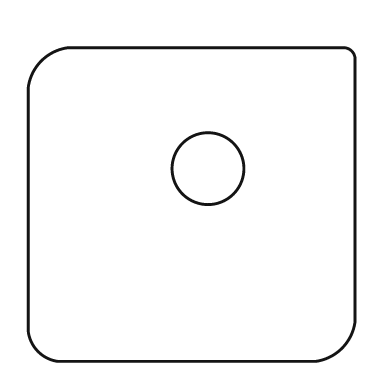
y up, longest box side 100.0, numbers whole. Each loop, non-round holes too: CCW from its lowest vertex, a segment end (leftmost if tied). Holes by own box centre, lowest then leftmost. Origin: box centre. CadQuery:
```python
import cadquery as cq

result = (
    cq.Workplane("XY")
    .moveTo(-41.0, -48.0)
    .lineTo(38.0, -48.0)
    .threePointArc((46.0, -44.0), (50.0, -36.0))
    .lineTo(50.0, 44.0)
    .threePointArc((49.0, 47.0), (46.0, 48.0))
    .lineTo(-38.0, 48.0)
    .threePointArc((-46.0, 44.0), (-50.0, 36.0))
    .lineTo(-50.0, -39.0)
    .threePointArc((-47.0, -45.0), (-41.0, -48.0))
    .close()
    .moveTo(5.0, 11.0)
    .circle(11.0)
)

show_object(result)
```